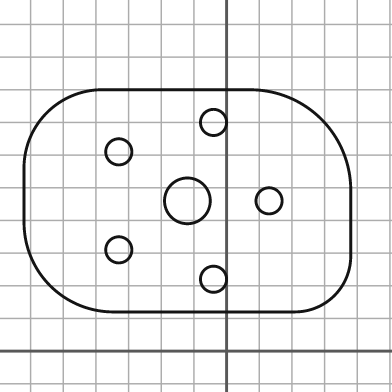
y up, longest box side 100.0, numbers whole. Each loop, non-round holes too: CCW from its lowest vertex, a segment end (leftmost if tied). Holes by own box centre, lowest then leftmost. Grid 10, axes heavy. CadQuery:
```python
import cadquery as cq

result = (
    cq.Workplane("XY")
    .moveTo(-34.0, 12.0)
    .lineTo(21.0, 12.0)
    .threePointArc((33.0, 17.0), (38.0, 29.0))
    .lineTo(38.0, 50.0)
    .threePointArc((29.0, 71.0), (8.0, 80.0))
    .lineTo(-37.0, 80.0)
    .threePointArc((-55.0, 73.0), (-62.0, 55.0))
    .lineTo(-62.0, 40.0)
    .threePointArc((-54.0, 20.0), (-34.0, 12.0))
    .close()
    .moveTo(-4.0, 22.0)
    .circle(4.0)
    .moveTo(-33.0, 31.0)
    .circle(4.0)
    .moveTo(-12.0, 46.0)
    .circle(7.0)
    .moveTo(13.0, 46.0)
    .circle(4.0)
    .moveTo(-33.0, 61.0)
    .circle(4.0)
    .moveTo(-4.0, 70.0)
    .circle(4.0)
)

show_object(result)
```